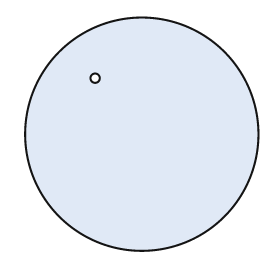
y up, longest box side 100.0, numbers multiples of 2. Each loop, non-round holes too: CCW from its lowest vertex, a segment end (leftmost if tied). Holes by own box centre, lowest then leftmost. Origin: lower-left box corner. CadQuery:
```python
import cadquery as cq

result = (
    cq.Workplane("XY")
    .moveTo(50.0, 50.0)
    .circle(50.0)
    .moveTo(30.0, 74.0)
    .circle(2.0)
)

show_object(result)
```